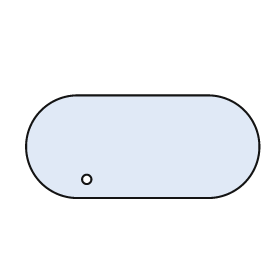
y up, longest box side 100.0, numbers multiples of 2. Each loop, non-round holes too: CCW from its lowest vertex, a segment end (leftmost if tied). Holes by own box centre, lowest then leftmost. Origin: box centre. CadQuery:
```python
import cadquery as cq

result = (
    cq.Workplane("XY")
    .moveTo(-28.0, -22.0)
    .lineTo(28.0, -22.0)
    .threePointArc((50.0, 0.0), (28.0, 22.0))
    .lineTo(-28.0, 22.0)
    .threePointArc((-50.0, 0.0), (-28.0, -22.0))
    .close()
    .moveTo(-24.0, -14.0)
    .circle(2.0)
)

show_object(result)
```